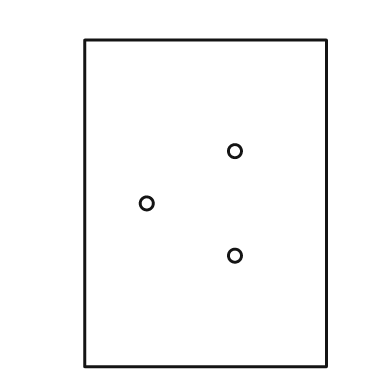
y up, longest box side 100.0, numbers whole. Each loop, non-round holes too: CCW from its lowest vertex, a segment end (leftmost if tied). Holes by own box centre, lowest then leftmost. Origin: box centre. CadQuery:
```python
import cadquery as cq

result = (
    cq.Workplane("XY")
    .moveTo(-37.0, -50.0)
    .lineTo(37.0, -50.0)
    .lineTo(37.0, 50.0)
    .lineTo(-37.0, 50.0)
    .close()
    .moveTo(9.0, -16.0)
    .circle(2.0)
    .moveTo(-18.0, 0.0)
    .circle(2.0)
    .moveTo(9.0, 16.0)
    .circle(2.0)
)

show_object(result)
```